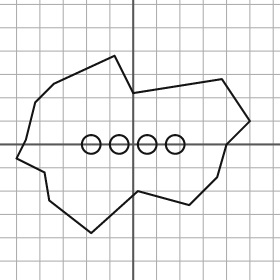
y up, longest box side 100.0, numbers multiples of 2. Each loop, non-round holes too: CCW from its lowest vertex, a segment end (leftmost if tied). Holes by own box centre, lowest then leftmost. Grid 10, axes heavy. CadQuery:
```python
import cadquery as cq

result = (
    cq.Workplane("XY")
    .moveTo(-18.0, -38.0)
    .lineTo(2.0, -20.0)
    .lineTo(24.0, -26.0)
    .lineTo(36.0, -14.0)
    .lineTo(40.0, 0.0)
    .lineTo(50.0, 10.0)
    .lineTo(38.0, 28.0)
    .lineTo(0.0, 22.0)
    .lineTo(-8.0, 38.0)
    .lineTo(-34.0, 26.0)
    .lineTo(-42.0, 18.0)
    .lineTo(-46.0, 2.0)
    .lineTo(-50.0, -6.0)
    .lineTo(-38.0, -12.0)
    .lineTo(-36.0, -24.0)
    .close()
    .moveTo(-18.0, 0.0)
    .circle(4.0)
    .moveTo(-6.0, 0.0)
    .circle(4.0)
    .moveTo(6.0, 0.0)
    .circle(4.0)
    .moveTo(18.0, 0.0)
    .circle(4.0)
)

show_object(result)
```